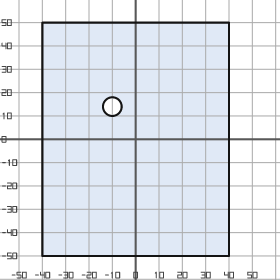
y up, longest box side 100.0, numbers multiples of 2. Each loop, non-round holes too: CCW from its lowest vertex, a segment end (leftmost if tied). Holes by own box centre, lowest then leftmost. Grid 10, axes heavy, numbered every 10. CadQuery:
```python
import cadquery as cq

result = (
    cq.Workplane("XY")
    .moveTo(-40.0, -50.0)
    .lineTo(40.0, -50.0)
    .lineTo(40.0, 50.0)
    .lineTo(-40.0, 50.0)
    .close()
    .moveTo(-10.0, 14.0)
    .circle(4.0)
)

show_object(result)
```